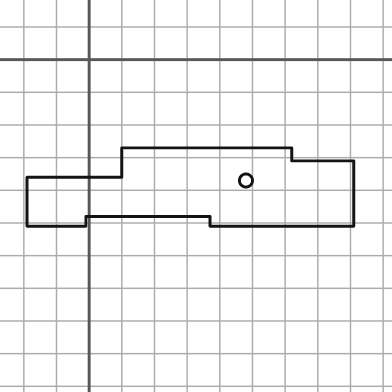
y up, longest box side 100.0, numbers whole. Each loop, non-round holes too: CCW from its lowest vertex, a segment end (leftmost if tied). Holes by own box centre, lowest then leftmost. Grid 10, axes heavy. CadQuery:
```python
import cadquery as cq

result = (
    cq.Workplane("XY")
    .moveTo(-19.0, -51.0)
    .lineTo(-1.0, -51.0)
    .lineTo(-1.0, -48.0)
    .lineTo(37.0, -48.0)
    .lineTo(37.0, -51.0)
    .lineTo(81.0, -51.0)
    .lineTo(81.0, -31.0)
    .lineTo(62.0, -31.0)
    .lineTo(62.0, -27.0)
    .lineTo(10.0, -27.0)
    .lineTo(10.0, -36.0)
    .lineTo(-19.0, -36.0)
    .close()
    .moveTo(48.0, -37.0)
    .circle(2.0)
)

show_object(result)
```